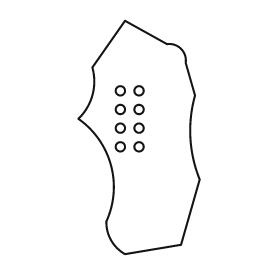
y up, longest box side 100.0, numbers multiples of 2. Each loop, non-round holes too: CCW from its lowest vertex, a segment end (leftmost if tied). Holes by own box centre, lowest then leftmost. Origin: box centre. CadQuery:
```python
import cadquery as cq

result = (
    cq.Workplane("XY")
    .moveTo(-6.0, -50.0)
    .lineTo(18.0, -46.0)
    .lineTo(26.0, -18.0)
    .threePointArc((22.0, 0.0), (24.0, 18.0))
    .lineTo(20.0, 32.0)
    .threePointArc((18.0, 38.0), (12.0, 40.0))
    .lineTo(-6.0, 50.0)
    .lineTo(-20.0, 30.0)
    .threePointArc((-20.0, 18.0), (-26.0, 8.0))
    .threePointArc((-12.0, -12.0), (-14.0, -36.0))
    .threePointArc((-12.0, -44.0), (-6.0, -50.0))
    .close()
    .moveTo(-8.0, -4.0)
    .circle(2.0)
    .moveTo(0.0, -4.0)
    .circle(2.0)
    .moveTo(-8.0, 4.0)
    .circle(2.0)
    .moveTo(0.0, 4.0)
    .circle(2.0)
    .moveTo(-8.0, 12.0)
    .circle(2.0)
    .moveTo(0.0, 12.0)
    .circle(2.0)
    .moveTo(-8.0, 20.0)
    .circle(2.0)
    .moveTo(0.0, 20.0)
    .circle(2.0)
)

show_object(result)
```